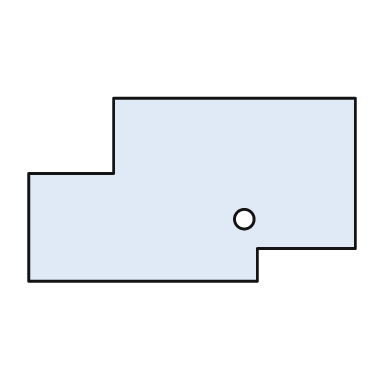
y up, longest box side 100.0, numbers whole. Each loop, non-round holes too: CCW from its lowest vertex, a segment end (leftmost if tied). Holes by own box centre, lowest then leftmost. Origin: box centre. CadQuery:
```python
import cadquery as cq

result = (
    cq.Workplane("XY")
    .moveTo(-50.0, -28.0)
    .lineTo(20.0, -28.0)
    .lineTo(20.0, -18.0)
    .lineTo(50.0, -18.0)
    .lineTo(50.0, 28.0)
    .lineTo(-24.0, 28.0)
    .lineTo(-24.0, 5.0)
    .lineTo(-50.0, 5.0)
    .close()
    .moveTo(16.0, -9.0)
    .circle(3.0)
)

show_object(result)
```